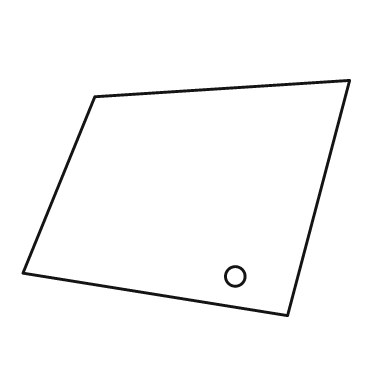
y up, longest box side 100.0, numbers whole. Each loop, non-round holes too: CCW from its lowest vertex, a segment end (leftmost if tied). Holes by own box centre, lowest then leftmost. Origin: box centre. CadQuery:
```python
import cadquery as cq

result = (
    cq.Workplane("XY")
    .moveTo(31.0, -36.0)
    .lineTo(50.0, 36.0)
    .lineTo(-28.0, 31.0)
    .lineTo(-50.0, -23.0)
    .close()
    .moveTo(15.0, -24.0)
    .circle(3.0)
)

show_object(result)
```